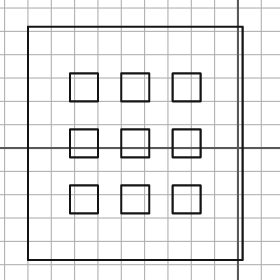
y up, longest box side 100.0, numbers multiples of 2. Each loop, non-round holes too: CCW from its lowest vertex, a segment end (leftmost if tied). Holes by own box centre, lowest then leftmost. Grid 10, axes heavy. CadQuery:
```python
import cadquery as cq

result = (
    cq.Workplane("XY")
    .moveTo(-90.0, -48.0)
    .lineTo(2.0, -48.0)
    .lineTo(2.0, 52.0)
    .lineTo(-90.0, 52.0)
    .close()
    .moveTo(-72.0, -28.0)
    .lineTo(-60.0, -28.0)
    .lineTo(-60.0, -16.0)
    .lineTo(-72.0, -16.0)
    .close()
    .moveTo(-50.0, -28.0)
    .lineTo(-38.0, -28.0)
    .lineTo(-38.0, -16.0)
    .lineTo(-50.0, -16.0)
    .close()
    .moveTo(-28.0, -28.0)
    .lineTo(-16.0, -28.0)
    .lineTo(-16.0, -16.0)
    .lineTo(-28.0, -16.0)
    .close()
    .moveTo(-72.0, -4.0)
    .lineTo(-60.0, -4.0)
    .lineTo(-60.0, 8.0)
    .lineTo(-72.0, 8.0)
    .close()
    .moveTo(-50.0, -4.0)
    .lineTo(-38.0, -4.0)
    .lineTo(-38.0, 8.0)
    .lineTo(-50.0, 8.0)
    .close()
    .moveTo(-28.0, -4.0)
    .lineTo(-16.0, -4.0)
    .lineTo(-16.0, 8.0)
    .lineTo(-28.0, 8.0)
    .close()
    .moveTo(-72.0, 20.0)
    .lineTo(-60.0, 20.0)
    .lineTo(-60.0, 32.0)
    .lineTo(-72.0, 32.0)
    .close()
    .moveTo(-50.0, 20.0)
    .lineTo(-38.0, 20.0)
    .lineTo(-38.0, 32.0)
    .lineTo(-50.0, 32.0)
    .close()
    .moveTo(-28.0, 20.0)
    .lineTo(-16.0, 20.0)
    .lineTo(-16.0, 32.0)
    .lineTo(-28.0, 32.0)
    .close()
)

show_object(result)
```